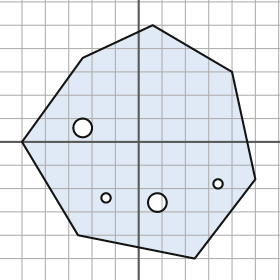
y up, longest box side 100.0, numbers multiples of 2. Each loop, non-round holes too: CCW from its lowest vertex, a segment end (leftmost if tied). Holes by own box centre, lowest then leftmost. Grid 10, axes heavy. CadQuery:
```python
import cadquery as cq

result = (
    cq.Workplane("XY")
    .moveTo(24.0, -50.0)
    .lineTo(50.0, -16.0)
    .lineTo(40.0, 30.0)
    .lineTo(6.0, 50.0)
    .lineTo(-24.0, 36.0)
    .lineTo(-50.0, 0.0)
    .lineTo(-26.0, -40.0)
    .close()
    .moveTo(8.0, -26.0)
    .circle(4.0)
    .moveTo(-14.0, -24.0)
    .circle(2.0)
    .moveTo(34.0, -18.0)
    .circle(2.0)
    .moveTo(-24.0, 6.0)
    .circle(4.0)
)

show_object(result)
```